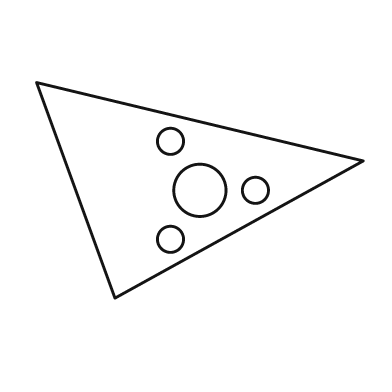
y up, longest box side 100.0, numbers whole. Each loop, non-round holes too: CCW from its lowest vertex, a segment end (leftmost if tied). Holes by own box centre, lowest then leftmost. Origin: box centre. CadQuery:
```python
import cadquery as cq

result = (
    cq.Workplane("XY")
    .moveTo(-26.0, -33.0)
    .lineTo(50.0, 9.0)
    .lineTo(-50.0, 33.0)
    .close()
    .moveTo(-9.0, -15.0)
    .circle(4.0)
    .moveTo(0.0, 0.0)
    .circle(8.0)
    .moveTo(17.0, 0.0)
    .circle(4.0)
    .moveTo(-9.0, 15.0)
    .circle(4.0)
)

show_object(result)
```